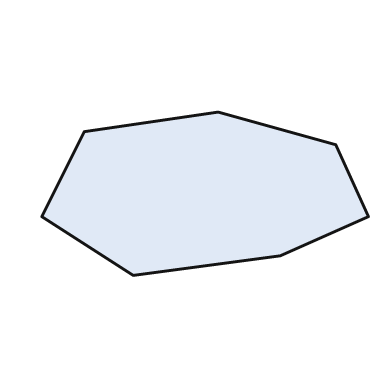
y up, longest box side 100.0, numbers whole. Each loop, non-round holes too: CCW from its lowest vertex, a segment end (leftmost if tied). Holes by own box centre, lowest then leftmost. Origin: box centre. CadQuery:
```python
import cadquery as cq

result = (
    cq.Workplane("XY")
    .moveTo(-22.0, -25.0)
    .lineTo(23.0, -19.0)
    .lineTo(50.0, -7.0)
    .lineTo(40.0, 15.0)
    .lineTo(4.0, 25.0)
    .lineTo(-37.0, 19.0)
    .lineTo(-50.0, -7.0)
    .close()
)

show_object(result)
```